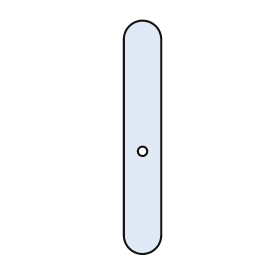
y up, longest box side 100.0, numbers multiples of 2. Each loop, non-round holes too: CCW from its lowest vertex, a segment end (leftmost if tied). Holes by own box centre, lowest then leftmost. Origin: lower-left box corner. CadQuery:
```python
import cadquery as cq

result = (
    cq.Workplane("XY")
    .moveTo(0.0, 8.0)
    .threePointArc((8.0, 0.0), (16.0, 8.0))
    .lineTo(16.0, 92.0)
    .threePointArc((8.0, 100.0), (0.0, 92.0))
    .close()
    .moveTo(8.0, 44.0)
    .circle(2.0)
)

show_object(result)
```